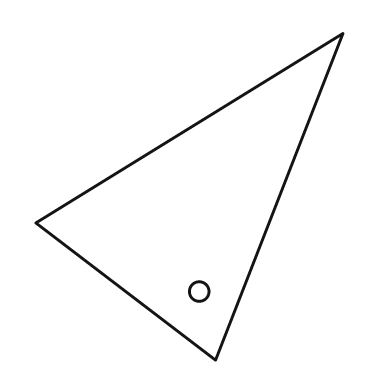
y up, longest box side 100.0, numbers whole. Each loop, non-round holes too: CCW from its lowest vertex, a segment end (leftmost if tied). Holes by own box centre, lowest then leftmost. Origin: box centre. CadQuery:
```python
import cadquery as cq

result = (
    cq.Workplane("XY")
    .moveTo(8.0, -50.0)
    .lineTo(47.0, 50.0)
    .lineTo(-47.0, -8.0)
    .close()
    .moveTo(3.0, -29.0)
    .circle(3.0)
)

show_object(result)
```